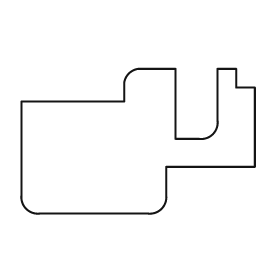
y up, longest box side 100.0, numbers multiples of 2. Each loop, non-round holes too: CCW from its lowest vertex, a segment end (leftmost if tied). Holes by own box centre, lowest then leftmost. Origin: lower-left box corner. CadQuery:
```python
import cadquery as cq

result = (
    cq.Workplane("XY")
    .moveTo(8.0, 0.0)
    .lineTo(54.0, 0.0)
    .threePointArc((60.0, 2.0), (62.0, 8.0))
    .lineTo(62.0, 20.0)
    .lineTo(100.0, 20.0)
    .lineTo(100.0, 54.0)
    .lineTo(92.0, 54.0)
    .lineTo(92.0, 62.0)
    .lineTo(84.0, 62.0)
    .lineTo(84.0, 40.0)
    .threePointArc((82.0, 34.0), (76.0, 32.0))
    .lineTo(66.0, 32.0)
    .lineTo(66.0, 62.0)
    .lineTo(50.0, 62.0)
    .threePointArc((46.0, 60.0), (44.0, 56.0))
    .lineTo(44.0, 48.0)
    .lineTo(0.0, 48.0)
    .lineTo(0.0, 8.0)
    .threePointArc((2.0, 2.0), (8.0, 0.0))
    .close()
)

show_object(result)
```